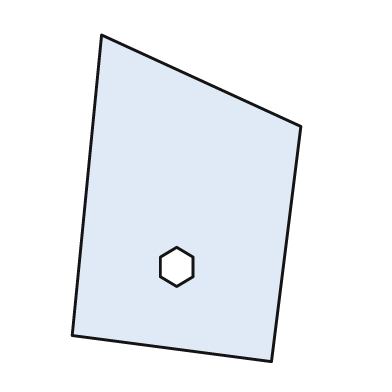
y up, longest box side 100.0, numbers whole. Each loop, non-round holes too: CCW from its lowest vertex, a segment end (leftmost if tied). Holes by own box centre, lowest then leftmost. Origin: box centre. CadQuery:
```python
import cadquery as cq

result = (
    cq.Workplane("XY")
    .moveTo(26.0, -50.0)
    .lineTo(35.0, 22.0)
    .lineTo(-26.0, 50.0)
    .lineTo(-35.0, -42.0)
    .close()
    .moveTo(-3.0, -27.0)
    .lineTo(2.0, -24.0)
    .lineTo(2.0, -18.0)
    .lineTo(-3.0, -15.0)
    .lineTo(-8.0, -18.0)
    .lineTo(-8.0, -24.0)
    .close()
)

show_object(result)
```